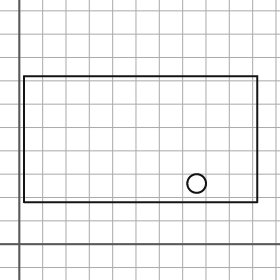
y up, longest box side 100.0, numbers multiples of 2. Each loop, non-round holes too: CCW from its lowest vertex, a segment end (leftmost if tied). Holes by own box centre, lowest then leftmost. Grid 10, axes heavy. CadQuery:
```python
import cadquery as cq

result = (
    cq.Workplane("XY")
    .moveTo(2.0, 18.0)
    .lineTo(102.0, 18.0)
    .lineTo(102.0, 72.0)
    .lineTo(2.0, 72.0)
    .close()
    .moveTo(76.0, 26.0)
    .circle(4.0)
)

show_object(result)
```